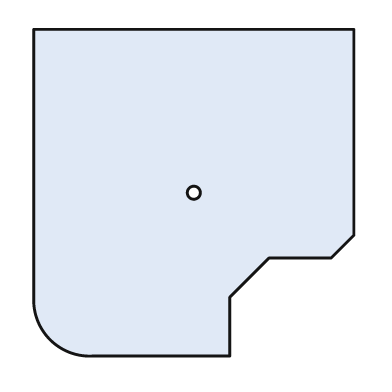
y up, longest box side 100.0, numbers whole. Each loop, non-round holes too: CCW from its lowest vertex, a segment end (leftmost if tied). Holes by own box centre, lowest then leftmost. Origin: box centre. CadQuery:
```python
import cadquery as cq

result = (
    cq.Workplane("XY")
    .moveTo(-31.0, -50.0)
    .lineTo(11.0, -50.0)
    .lineTo(11.0, -32.0)
    .lineTo(23.0, -20.0)
    .lineTo(42.0, -20.0)
    .lineTo(49.0, -13.0)
    .lineTo(49.0, 50.0)
    .lineTo(-49.0, 50.0)
    .lineTo(-49.0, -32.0)
    .threePointArc((-44.0, -45.0), (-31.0, -50.0))
    .close()
    .moveTo(0.0, 0.0)
    .circle(2.0)
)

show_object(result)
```